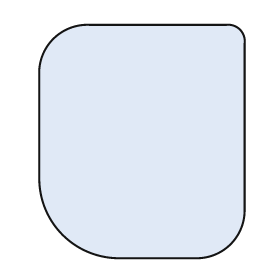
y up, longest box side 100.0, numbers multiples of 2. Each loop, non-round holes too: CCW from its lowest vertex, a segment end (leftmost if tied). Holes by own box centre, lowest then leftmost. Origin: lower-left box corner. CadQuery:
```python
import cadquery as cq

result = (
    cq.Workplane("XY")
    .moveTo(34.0, 0.0)
    .lineTo(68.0, 0.0)
    .threePointArc((82.0, 6.0), (88.0, 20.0))
    .lineTo(88.0, 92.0)
    .threePointArc((86.0, 98.0), (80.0, 100.0))
    .lineTo(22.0, 100.0)
    .threePointArc((6.0, 94.0), (0.0, 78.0))
    .lineTo(0.0, 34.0)
    .threePointArc((10.0, 10.0), (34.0, 0.0))
    .close()
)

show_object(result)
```